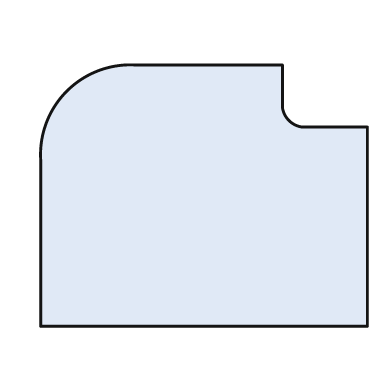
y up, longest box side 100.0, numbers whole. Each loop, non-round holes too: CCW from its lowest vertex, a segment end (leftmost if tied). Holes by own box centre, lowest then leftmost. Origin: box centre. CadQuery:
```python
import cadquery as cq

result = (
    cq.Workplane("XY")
    .moveTo(-50.0, -40.0)
    .lineTo(50.0, -40.0)
    .lineTo(50.0, 21.0)
    .lineTo(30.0, 21.0)
    .threePointArc((26.0, 23.0), (24.0, 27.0))
    .lineTo(24.0, 40.0)
    .lineTo(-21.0, 40.0)
    .threePointArc((-42.0, 32.0), (-50.0, 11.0))
    .close()
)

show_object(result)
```